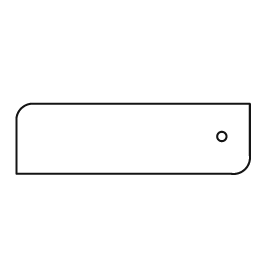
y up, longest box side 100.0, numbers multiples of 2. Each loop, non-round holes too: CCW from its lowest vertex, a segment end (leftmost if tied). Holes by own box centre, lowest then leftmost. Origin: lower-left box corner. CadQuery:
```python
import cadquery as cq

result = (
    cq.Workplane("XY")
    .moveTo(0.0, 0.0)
    .lineTo(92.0, 0.0)
    .threePointArc((98.0, 2.0), (100.0, 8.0))
    .lineTo(100.0, 30.0)
    .lineTo(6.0, 30.0)
    .threePointArc((2.0, 28.0), (0.0, 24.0))
    .close()
    .moveTo(88.0, 16.0)
    .circle(2.0)
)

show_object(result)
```